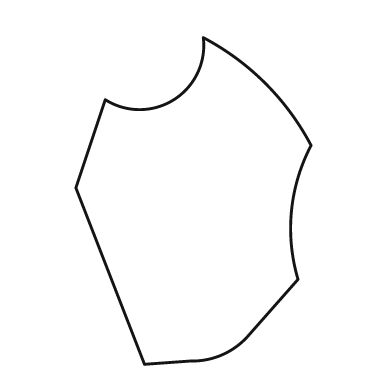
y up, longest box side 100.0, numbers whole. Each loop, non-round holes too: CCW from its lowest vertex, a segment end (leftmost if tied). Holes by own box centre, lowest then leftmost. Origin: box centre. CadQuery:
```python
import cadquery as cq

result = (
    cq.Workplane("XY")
    .moveTo(-15.0, -50.0)
    .lineTo(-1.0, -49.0)
    .threePointArc((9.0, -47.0), (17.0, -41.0))
    .lineTo(32.0, -24.0)
    .threePointArc((30.0, -3.0), (36.0, 17.0))
    .threePointArc((22.0, 36.0), (3.0, 50.0))
    .threePointArc((-6.0, 31.0), (-27.0, 31.0))
    .lineTo(-36.0, 4.0)
    .close()
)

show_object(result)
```